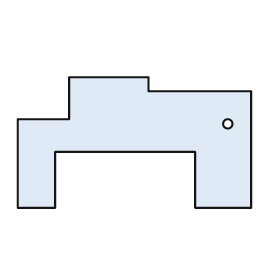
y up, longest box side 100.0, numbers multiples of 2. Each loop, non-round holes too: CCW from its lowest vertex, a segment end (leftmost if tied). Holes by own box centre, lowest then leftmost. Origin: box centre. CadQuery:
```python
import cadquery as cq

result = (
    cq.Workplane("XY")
    .moveTo(-50.0, -28.0)
    .lineTo(-34.0, -28.0)
    .lineTo(-34.0, -4.0)
    .lineTo(26.0, -4.0)
    .lineTo(26.0, -28.0)
    .lineTo(50.0, -28.0)
    .lineTo(50.0, 22.0)
    .lineTo(6.0, 22.0)
    .lineTo(6.0, 28.0)
    .lineTo(-28.0, 28.0)
    .lineTo(-28.0, 10.0)
    .lineTo(-50.0, 10.0)
    .close()
    .moveTo(40.0, 8.0)
    .circle(2.0)
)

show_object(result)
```